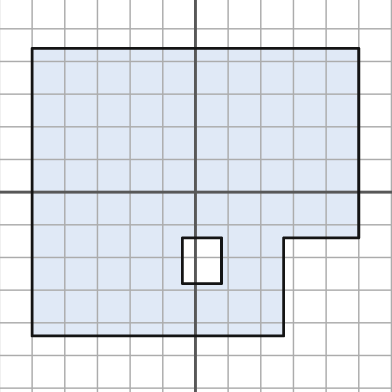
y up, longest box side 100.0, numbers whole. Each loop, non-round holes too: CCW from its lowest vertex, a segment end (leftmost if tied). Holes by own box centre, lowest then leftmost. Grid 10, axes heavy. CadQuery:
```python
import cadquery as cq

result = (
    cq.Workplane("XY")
    .moveTo(-50.0, -44.0)
    .lineTo(27.0, -44.0)
    .lineTo(27.0, -14.0)
    .lineTo(50.0, -14.0)
    .lineTo(50.0, 44.0)
    .lineTo(-50.0, 44.0)
    .close()
    .moveTo(-4.0, -28.0)
    .lineTo(8.0, -28.0)
    .lineTo(8.0, -14.0)
    .lineTo(-4.0, -14.0)
    .close()
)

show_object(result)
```